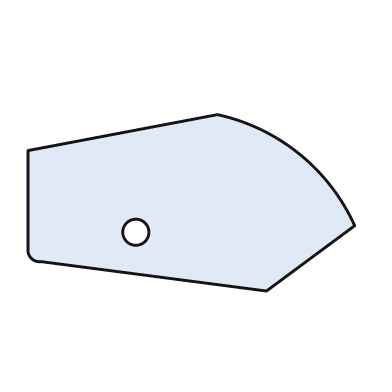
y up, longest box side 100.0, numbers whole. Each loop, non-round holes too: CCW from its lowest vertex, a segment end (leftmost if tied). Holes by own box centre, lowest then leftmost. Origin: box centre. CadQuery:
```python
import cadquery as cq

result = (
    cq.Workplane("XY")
    .moveTo(23.0, -27.0)
    .lineTo(50.0, -7.0)
    .threePointArc((33.0, 15.0), (8.0, 27.0))
    .lineTo(-50.0, 16.0)
    .lineTo(-50.0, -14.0)
    .threePointArc((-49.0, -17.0), (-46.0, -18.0))
    .close()
    .moveTo(-17.0, -9.0)
    .circle(4.0)
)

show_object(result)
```